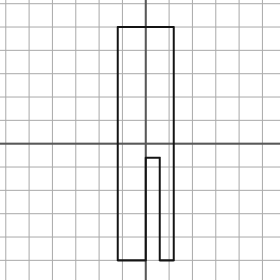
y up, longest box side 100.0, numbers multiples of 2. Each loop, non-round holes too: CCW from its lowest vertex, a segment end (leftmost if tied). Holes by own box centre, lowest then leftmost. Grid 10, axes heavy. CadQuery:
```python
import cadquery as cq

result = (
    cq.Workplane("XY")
    .moveTo(-12.0, -50.0)
    .lineTo(0.0, -50.0)
    .lineTo(0.0, -6.0)
    .lineTo(6.0, -6.0)
    .lineTo(6.0, -50.0)
    .lineTo(12.0, -50.0)
    .lineTo(12.0, 50.0)
    .lineTo(-12.0, 50.0)
    .close()
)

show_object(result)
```